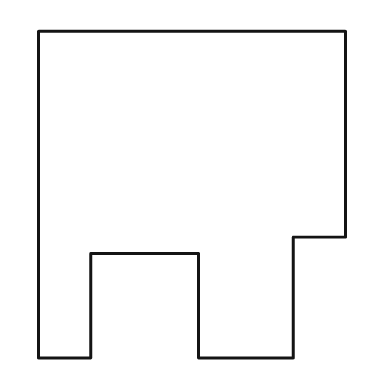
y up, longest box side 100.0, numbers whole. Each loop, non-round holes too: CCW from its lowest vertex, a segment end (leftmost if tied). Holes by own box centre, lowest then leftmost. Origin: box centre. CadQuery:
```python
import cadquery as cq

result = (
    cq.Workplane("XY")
    .moveTo(-47.0, -50.0)
    .lineTo(-31.0, -50.0)
    .lineTo(-31.0, -18.0)
    .lineTo(2.0, -18.0)
    .lineTo(2.0, -50.0)
    .lineTo(31.0, -50.0)
    .lineTo(31.0, -13.0)
    .lineTo(47.0, -13.0)
    .lineTo(47.0, 50.0)
    .lineTo(-47.0, 50.0)
    .close()
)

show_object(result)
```